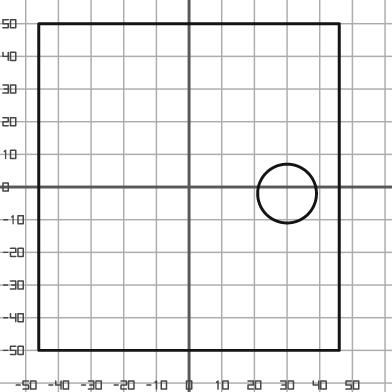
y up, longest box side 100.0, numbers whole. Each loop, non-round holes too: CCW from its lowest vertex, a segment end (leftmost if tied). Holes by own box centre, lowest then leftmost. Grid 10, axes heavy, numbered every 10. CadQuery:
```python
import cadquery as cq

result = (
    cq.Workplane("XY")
    .moveTo(-46.0, -50.0)
    .lineTo(46.0, -50.0)
    .lineTo(46.0, 50.0)
    .lineTo(-46.0, 50.0)
    .close()
    .moveTo(30.0, -2.0)
    .circle(9.0)
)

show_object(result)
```